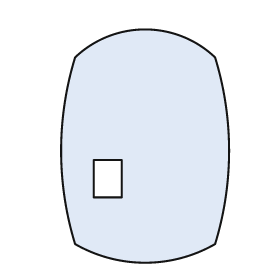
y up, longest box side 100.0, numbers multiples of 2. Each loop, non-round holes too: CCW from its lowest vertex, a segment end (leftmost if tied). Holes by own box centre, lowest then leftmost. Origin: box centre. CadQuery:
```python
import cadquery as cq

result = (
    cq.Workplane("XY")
    .moveTo(-30.0, -42.0)
    .threePointArc((0.0, -50.0), (30.0, -42.0))
    .threePointArc((36.0, -2.0), (30.0, 38.0))
    .threePointArc((0.0, 50.0), (-30.0, 38.0))
    .threePointArc((-36.0, -2.0), (-30.0, -42.0))
    .close()
    .moveTo(-22.0, -22.0)
    .lineTo(-10.0, -22.0)
    .lineTo(-10.0, -6.0)
    .lineTo(-22.0, -6.0)
    .close()
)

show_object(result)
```